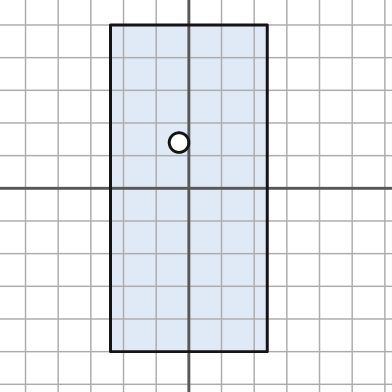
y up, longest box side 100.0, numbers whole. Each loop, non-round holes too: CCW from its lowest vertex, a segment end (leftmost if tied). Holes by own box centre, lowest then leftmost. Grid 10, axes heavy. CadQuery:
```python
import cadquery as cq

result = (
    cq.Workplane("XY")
    .moveTo(-24.0, -50.0)
    .lineTo(24.0, -50.0)
    .lineTo(24.0, 50.0)
    .lineTo(-24.0, 50.0)
    .close()
    .moveTo(-3.0, 14.0)
    .circle(3.0)
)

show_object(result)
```